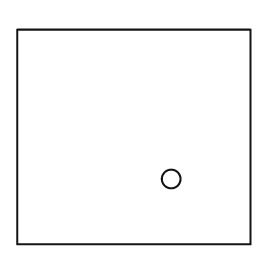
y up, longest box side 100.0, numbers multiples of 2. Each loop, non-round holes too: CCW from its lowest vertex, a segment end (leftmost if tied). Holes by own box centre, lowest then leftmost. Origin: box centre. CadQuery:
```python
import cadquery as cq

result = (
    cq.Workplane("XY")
    .moveTo(-50.0, -46.0)
    .lineTo(50.0, -46.0)
    .lineTo(50.0, 46.0)
    .lineTo(-50.0, 46.0)
    .close()
    .moveTo(16.0, -18.0)
    .circle(4.0)
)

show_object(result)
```